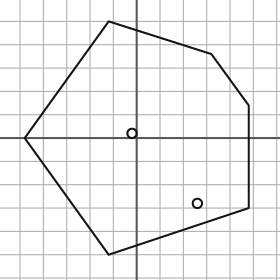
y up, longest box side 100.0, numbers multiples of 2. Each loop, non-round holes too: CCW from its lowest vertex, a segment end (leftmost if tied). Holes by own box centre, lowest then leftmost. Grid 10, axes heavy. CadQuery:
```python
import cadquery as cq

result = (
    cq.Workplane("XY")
    .moveTo(-12.0, -50.0)
    .lineTo(48.0, -30.0)
    .lineTo(48.0, 14.0)
    .lineTo(32.0, 36.0)
    .lineTo(-12.0, 50.0)
    .lineTo(-48.0, 0.0)
    .close()
    .moveTo(26.0, -28.0)
    .circle(2.0)
    .moveTo(-2.0, 2.0)
    .circle(2.0)
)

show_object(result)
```